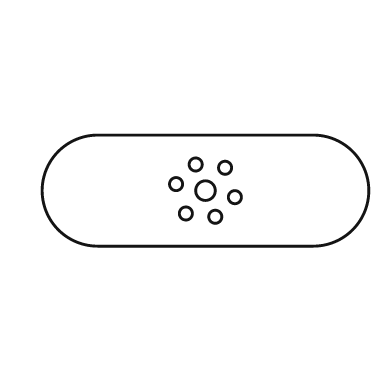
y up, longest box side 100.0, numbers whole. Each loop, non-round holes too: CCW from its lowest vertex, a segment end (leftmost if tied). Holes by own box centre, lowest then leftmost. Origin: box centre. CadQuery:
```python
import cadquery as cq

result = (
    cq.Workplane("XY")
    .moveTo(-33.0, -17.0)
    .lineTo(33.0, -17.0)
    .threePointArc((50.0, 0.0), (33.0, 17.0))
    .lineTo(-33.0, 17.0)
    .threePointArc((-50.0, 0.0), (-33.0, -17.0))
    .close()
    .moveTo(3.0, -8.0)
    .circle(2.0)
    .moveTo(-6.0, -7.0)
    .circle(2.0)
    .moveTo(9.0, -2.0)
    .circle(2.0)
    .moveTo(0.0, 0.0)
    .circle(3.0)
    .moveTo(-9.0, 2.0)
    .circle(2.0)
    .moveTo(6.0, 7.0)
    .circle(2.0)
    .moveTo(-3.0, 8.0)
    .circle(2.0)
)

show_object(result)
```